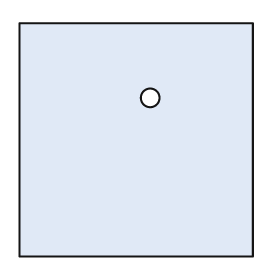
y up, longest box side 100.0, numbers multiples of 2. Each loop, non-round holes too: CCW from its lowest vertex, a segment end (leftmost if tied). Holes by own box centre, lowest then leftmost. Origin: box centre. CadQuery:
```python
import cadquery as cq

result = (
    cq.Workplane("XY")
    .moveTo(-50.0, -50.0)
    .lineTo(50.0, -50.0)
    .lineTo(50.0, 50.0)
    .lineTo(-50.0, 50.0)
    .close()
    .moveTo(6.0, 18.0)
    .circle(4.0)
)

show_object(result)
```